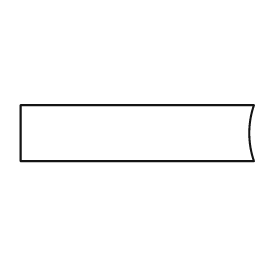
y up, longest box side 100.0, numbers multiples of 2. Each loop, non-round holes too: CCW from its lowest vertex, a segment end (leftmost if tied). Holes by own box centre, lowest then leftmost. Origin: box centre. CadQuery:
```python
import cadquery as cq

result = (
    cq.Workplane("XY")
    .moveTo(-50.0, -12.0)
    .lineTo(50.0, -12.0)
    .threePointArc((48.0, 0.0), (50.0, 12.0))
    .lineTo(-50.0, 12.0)
    .close()
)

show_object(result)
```